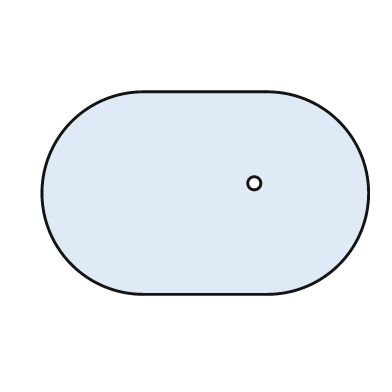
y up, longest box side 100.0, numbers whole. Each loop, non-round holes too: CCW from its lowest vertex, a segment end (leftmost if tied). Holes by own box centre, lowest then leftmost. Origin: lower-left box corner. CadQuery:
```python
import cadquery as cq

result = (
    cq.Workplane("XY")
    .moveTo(31.0, 0.0)
    .lineTo(69.0, 0.0)
    .threePointArc((100.0, 31.0), (69.0, 62.0))
    .lineTo(31.0, 62.0)
    .threePointArc((0.0, 31.0), (31.0, 0.0))
    .close()
    .moveTo(65.0, 34.0)
    .circle(2.0)
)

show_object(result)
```